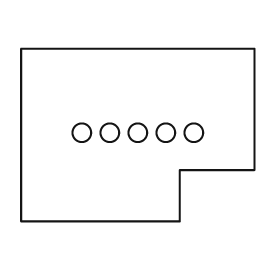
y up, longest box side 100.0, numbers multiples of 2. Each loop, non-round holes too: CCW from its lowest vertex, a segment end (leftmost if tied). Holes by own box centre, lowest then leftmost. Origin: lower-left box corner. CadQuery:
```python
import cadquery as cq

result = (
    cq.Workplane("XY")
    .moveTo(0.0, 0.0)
    .lineTo(68.0, 0.0)
    .lineTo(68.0, 22.0)
    .lineTo(100.0, 22.0)
    .lineTo(100.0, 74.0)
    .lineTo(0.0, 74.0)
    .close()
    .moveTo(26.0, 38.0)
    .circle(4.0)
    .moveTo(38.0, 38.0)
    .circle(4.0)
    .moveTo(50.0, 38.0)
    .circle(4.0)
    .moveTo(62.0, 38.0)
    .circle(4.0)
    .moveTo(74.0, 38.0)
    .circle(4.0)
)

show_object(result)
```